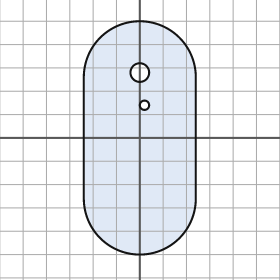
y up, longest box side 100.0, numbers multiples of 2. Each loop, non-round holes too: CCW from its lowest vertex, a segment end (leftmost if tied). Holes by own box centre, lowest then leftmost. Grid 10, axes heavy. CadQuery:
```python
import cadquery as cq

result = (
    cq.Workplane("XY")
    .moveTo(-24.0, -26.0)
    .threePointArc((0.0, -50.0), (24.0, -26.0))
    .lineTo(24.0, 26.0)
    .threePointArc((0.0, 50.0), (-24.0, 26.0))
    .close()
    .moveTo(2.0, 14.0)
    .circle(2.0)
    .moveTo(0.0, 28.0)
    .circle(4.0)
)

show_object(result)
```